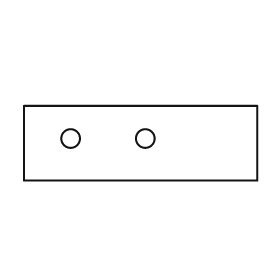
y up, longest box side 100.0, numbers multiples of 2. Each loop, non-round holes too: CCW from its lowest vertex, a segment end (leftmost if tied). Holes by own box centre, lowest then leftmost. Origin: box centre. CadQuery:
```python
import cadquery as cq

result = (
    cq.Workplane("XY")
    .moveTo(-50.0, -16.0)
    .lineTo(50.0, -16.0)
    .lineTo(50.0, 16.0)
    .lineTo(-50.0, 16.0)
    .close()
    .moveTo(-30.0, 2.0)
    .circle(4.0)
    .moveTo(2.0, 2.0)
    .circle(4.0)
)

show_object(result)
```